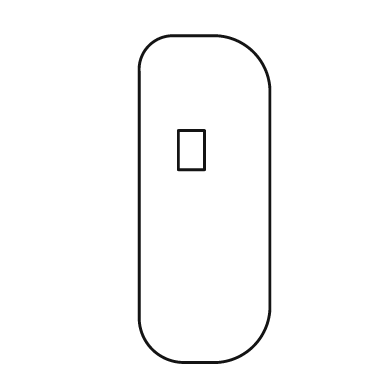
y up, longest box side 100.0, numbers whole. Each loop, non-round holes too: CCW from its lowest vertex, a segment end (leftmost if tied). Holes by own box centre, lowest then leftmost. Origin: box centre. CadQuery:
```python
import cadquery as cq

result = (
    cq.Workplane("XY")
    .moveTo(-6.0, -50.0)
    .lineTo(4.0, -50.0)
    .threePointArc((15.0, -45.0), (20.0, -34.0))
    .lineTo(20.0, 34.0)
    .threePointArc((15.0, 45.0), (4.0, 50.0))
    .lineTo(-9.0, 50.0)
    .threePointArc((-17.0, 47.0), (-20.0, 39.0))
    .lineTo(-20.0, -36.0)
    .threePointArc((-16.0, -46.0), (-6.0, -50.0))
    .close()
    .moveTo(-8.0, 9.0)
    .lineTo(0.0, 9.0)
    .lineTo(0.0, 21.0)
    .lineTo(-8.0, 21.0)
    .close()
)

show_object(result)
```